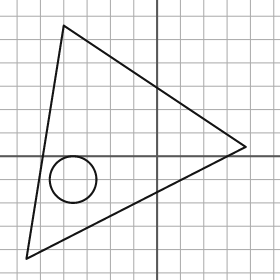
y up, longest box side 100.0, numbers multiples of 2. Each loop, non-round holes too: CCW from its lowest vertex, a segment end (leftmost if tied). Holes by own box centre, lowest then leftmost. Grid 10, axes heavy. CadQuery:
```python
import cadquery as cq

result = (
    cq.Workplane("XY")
    .moveTo(-56.0, -44.0)
    .lineTo(38.0, 4.0)
    .lineTo(-40.0, 56.0)
    .close()
    .moveTo(-36.0, -10.0)
    .circle(10.0)
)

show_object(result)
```